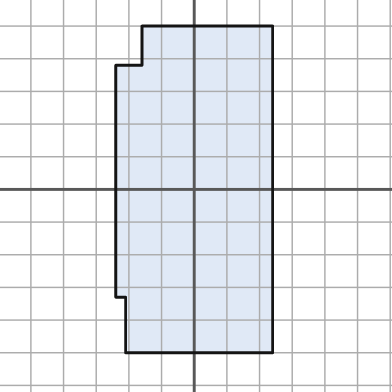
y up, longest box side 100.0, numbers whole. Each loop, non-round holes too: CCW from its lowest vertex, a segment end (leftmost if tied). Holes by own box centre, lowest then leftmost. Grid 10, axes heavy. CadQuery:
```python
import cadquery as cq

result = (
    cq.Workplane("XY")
    .moveTo(-21.0, -50.0)
    .lineTo(24.0, -50.0)
    .lineTo(24.0, 50.0)
    .lineTo(-16.0, 50.0)
    .lineTo(-16.0, 38.0)
    .lineTo(-24.0, 38.0)
    .lineTo(-24.0, -33.0)
    .lineTo(-21.0, -33.0)
    .close()
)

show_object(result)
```